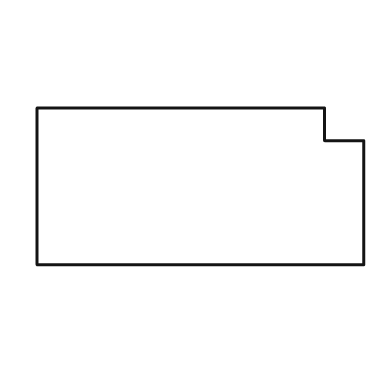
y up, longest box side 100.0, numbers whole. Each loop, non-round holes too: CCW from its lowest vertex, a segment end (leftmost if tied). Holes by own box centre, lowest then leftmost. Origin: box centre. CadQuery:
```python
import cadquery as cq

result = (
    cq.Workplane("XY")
    .moveTo(-50.0, -24.0)
    .lineTo(50.0, -24.0)
    .lineTo(50.0, 14.0)
    .lineTo(38.0, 14.0)
    .lineTo(38.0, 24.0)
    .lineTo(-50.0, 24.0)
    .close()
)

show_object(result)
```